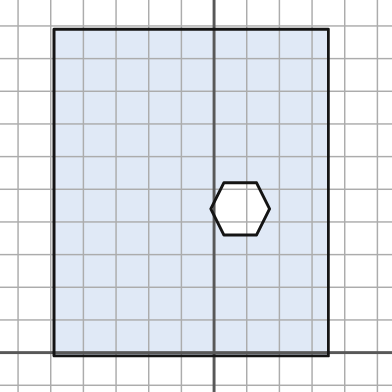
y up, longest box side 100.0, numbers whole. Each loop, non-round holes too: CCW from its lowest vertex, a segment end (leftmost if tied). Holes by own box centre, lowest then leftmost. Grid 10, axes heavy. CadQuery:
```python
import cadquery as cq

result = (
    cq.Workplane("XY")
    .moveTo(-49.0, -1.0)
    .lineTo(35.0, -1.0)
    .lineTo(35.0, 99.0)
    .lineTo(-49.0, 99.0)
    .close()
    .moveTo(3.0, 36.0)
    .lineTo(13.0, 36.0)
    .lineTo(17.0, 44.0)
    .lineTo(13.0, 52.0)
    .lineTo(3.0, 52.0)
    .lineTo(-1.0, 44.0)
    .close()
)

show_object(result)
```